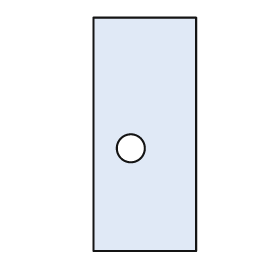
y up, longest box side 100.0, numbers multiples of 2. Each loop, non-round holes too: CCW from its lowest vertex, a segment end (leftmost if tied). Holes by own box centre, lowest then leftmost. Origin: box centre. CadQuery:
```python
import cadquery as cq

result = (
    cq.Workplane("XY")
    .moveTo(-22.0, -50.0)
    .lineTo(22.0, -50.0)
    .lineTo(22.0, 50.0)
    .lineTo(-22.0, 50.0)
    .close()
    .moveTo(-6.0, -6.0)
    .circle(6.0)
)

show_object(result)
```